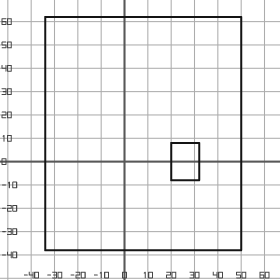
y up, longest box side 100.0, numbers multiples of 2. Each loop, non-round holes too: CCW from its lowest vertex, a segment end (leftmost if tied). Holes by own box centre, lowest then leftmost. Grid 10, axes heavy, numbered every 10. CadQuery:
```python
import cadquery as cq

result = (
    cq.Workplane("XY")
    .moveTo(-34.0, -38.0)
    .lineTo(50.0, -38.0)
    .lineTo(50.0, 62.0)
    .lineTo(-34.0, 62.0)
    .close()
    .moveTo(20.0, -8.0)
    .lineTo(32.0, -8.0)
    .lineTo(32.0, 8.0)
    .lineTo(20.0, 8.0)
    .close()
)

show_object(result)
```